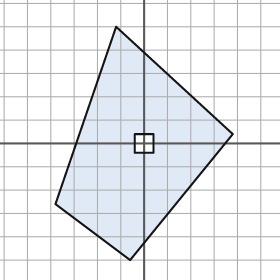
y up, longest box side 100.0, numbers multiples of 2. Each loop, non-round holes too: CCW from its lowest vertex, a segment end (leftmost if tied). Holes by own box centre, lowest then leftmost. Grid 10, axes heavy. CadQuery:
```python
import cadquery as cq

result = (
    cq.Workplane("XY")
    .moveTo(-6.0, -50.0)
    .lineTo(38.0, 4.0)
    .lineTo(-12.0, 50.0)
    .lineTo(-38.0, -26.0)
    .close()
    .moveTo(-4.0, -4.0)
    .lineTo(4.0, -4.0)
    .lineTo(4.0, 4.0)
    .lineTo(-4.0, 4.0)
    .close()
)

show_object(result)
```